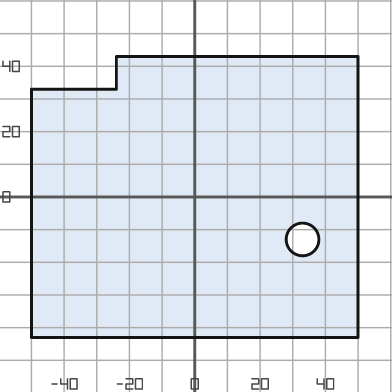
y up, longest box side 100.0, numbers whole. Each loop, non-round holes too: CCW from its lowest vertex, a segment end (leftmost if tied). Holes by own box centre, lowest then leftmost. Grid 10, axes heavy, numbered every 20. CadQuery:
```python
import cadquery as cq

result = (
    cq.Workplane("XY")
    .moveTo(-50.0, -43.0)
    .lineTo(50.0, -43.0)
    .lineTo(50.0, 43.0)
    .lineTo(-24.0, 43.0)
    .lineTo(-24.0, 33.0)
    .lineTo(-50.0, 33.0)
    .close()
    .moveTo(33.0, -13.0)
    .circle(5.0)
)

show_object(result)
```